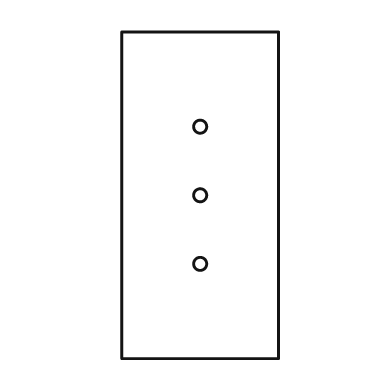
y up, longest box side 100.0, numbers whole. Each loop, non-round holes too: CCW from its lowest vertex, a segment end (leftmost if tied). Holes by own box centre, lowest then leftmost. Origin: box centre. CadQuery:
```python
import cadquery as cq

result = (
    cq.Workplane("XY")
    .moveTo(-24.0, -50.0)
    .lineTo(24.0, -50.0)
    .lineTo(24.0, 50.0)
    .lineTo(-24.0, 50.0)
    .close()
    .moveTo(0.0, -21.0)
    .circle(2.0)
    .moveTo(0.0, 0.0)
    .circle(2.0)
    .moveTo(0.0, 21.0)
    .circle(2.0)
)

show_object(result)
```